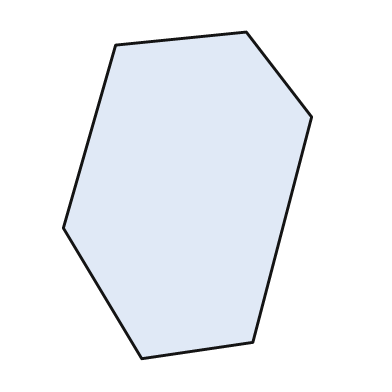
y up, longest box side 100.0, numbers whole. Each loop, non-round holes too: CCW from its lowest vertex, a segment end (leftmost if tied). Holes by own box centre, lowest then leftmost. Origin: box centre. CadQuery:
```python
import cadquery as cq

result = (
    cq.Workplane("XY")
    .moveTo(-14.0, -50.0)
    .lineTo(20.0, -45.0)
    .lineTo(38.0, 24.0)
    .lineTo(18.0, 50.0)
    .lineTo(-22.0, 46.0)
    .lineTo(-38.0, -10.0)
    .close()
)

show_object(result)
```